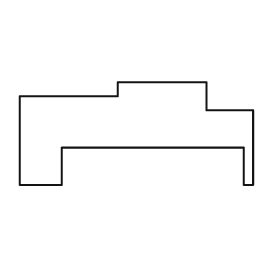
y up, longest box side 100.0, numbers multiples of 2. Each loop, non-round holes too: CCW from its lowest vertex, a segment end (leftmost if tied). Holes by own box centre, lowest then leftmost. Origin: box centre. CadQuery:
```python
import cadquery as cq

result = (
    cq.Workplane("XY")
    .moveTo(-50.0, -22.0)
    .lineTo(-32.0, -22.0)
    .lineTo(-32.0, -6.0)
    .lineTo(46.0, -6.0)
    .lineTo(46.0, -22.0)
    .lineTo(50.0, -22.0)
    .lineTo(50.0, 10.0)
    .lineTo(30.0, 10.0)
    .lineTo(30.0, 22.0)
    .lineTo(-8.0, 22.0)
    .lineTo(-8.0, 16.0)
    .lineTo(-50.0, 16.0)
    .close()
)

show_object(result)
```